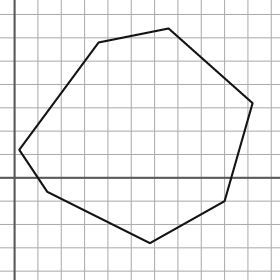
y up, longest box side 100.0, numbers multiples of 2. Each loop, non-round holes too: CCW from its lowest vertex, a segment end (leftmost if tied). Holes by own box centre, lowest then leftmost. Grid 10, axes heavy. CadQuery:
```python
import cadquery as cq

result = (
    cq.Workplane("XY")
    .moveTo(58.0, -28.0)
    .lineTo(90.0, -10.0)
    .lineTo(102.0, 32.0)
    .lineTo(66.0, 64.0)
    .lineTo(36.0, 58.0)
    .lineTo(2.0, 12.0)
    .lineTo(14.0, -6.0)
    .close()
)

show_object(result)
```